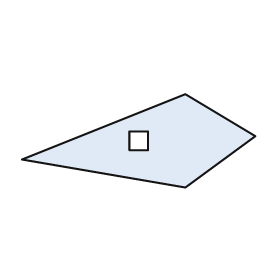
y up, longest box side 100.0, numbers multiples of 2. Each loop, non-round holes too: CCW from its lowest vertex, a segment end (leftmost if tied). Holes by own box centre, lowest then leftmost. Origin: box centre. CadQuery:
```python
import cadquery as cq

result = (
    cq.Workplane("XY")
    .moveTo(20.0, -20.0)
    .lineTo(50.0, 2.0)
    .lineTo(20.0, 20.0)
    .lineTo(-50.0, -8.0)
    .close()
    .moveTo(-4.0, -4.0)
    .lineTo(4.0, -4.0)
    .lineTo(4.0, 4.0)
    .lineTo(-4.0, 4.0)
    .close()
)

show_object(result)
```